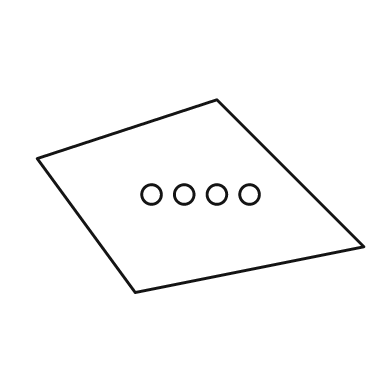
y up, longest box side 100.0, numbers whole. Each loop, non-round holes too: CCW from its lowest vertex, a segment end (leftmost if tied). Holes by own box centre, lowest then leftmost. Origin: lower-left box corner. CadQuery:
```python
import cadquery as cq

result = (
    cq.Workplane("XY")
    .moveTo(30.0, 0.0)
    .lineTo(100.0, 14.0)
    .lineTo(55.0, 59.0)
    .lineTo(0.0, 41.0)
    .close()
    .moveTo(35.0, 30.0)
    .circle(3.0)
    .moveTo(45.0, 30.0)
    .circle(3.0)
    .moveTo(55.0, 30.0)
    .circle(3.0)
    .moveTo(65.0, 30.0)
    .circle(3.0)
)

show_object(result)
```